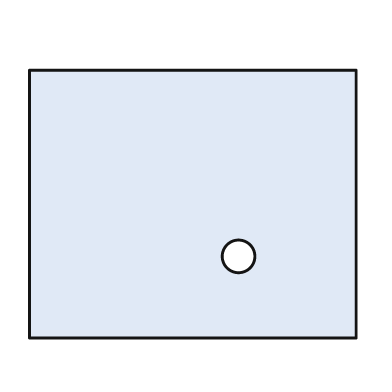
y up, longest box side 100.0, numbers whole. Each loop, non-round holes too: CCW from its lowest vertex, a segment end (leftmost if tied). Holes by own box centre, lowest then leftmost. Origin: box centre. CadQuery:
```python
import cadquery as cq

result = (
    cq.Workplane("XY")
    .moveTo(-50.0, -41.0)
    .lineTo(50.0, -41.0)
    .lineTo(50.0, 41.0)
    .lineTo(-50.0, 41.0)
    .close()
    .moveTo(14.0, -16.0)
    .circle(5.0)
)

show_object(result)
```